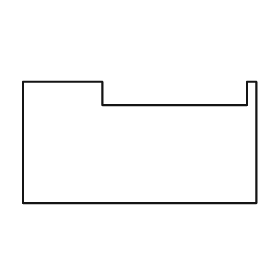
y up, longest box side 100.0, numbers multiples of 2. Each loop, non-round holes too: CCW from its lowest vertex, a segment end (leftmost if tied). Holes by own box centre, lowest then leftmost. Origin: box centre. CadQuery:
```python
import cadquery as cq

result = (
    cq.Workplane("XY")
    .moveTo(-50.0, -26.0)
    .lineTo(50.0, -26.0)
    .lineTo(50.0, 26.0)
    .lineTo(46.0, 26.0)
    .lineTo(46.0, 16.0)
    .lineTo(-16.0, 16.0)
    .lineTo(-16.0, 26.0)
    .lineTo(-50.0, 26.0)
    .close()
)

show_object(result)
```